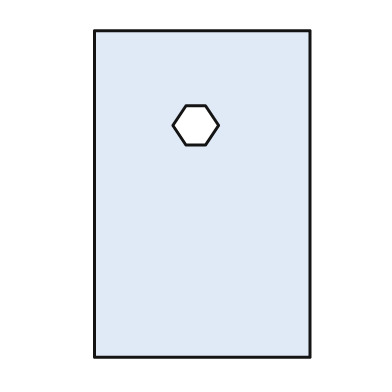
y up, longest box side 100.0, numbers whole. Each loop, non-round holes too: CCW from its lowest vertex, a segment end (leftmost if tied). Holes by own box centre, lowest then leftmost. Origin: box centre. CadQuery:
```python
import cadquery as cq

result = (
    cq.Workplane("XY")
    .moveTo(-33.0, -50.0)
    .lineTo(33.0, -50.0)
    .lineTo(33.0, 50.0)
    .lineTo(-33.0, 50.0)
    .close()
    .moveTo(-5.0, 15.0)
    .lineTo(1.0, 15.0)
    .lineTo(5.0, 21.0)
    .lineTo(1.0, 27.0)
    .lineTo(-5.0, 27.0)
    .lineTo(-9.0, 21.0)
    .close()
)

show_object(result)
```